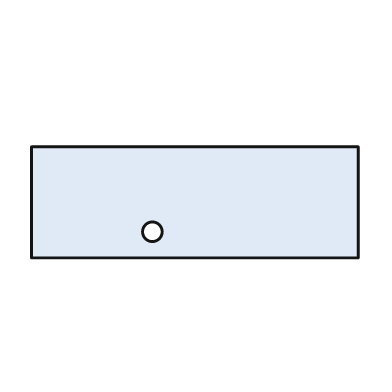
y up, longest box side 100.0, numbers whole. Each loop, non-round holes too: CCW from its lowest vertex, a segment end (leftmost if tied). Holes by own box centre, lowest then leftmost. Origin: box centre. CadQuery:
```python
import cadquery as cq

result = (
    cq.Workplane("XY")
    .moveTo(-50.0, -17.0)
    .lineTo(50.0, -17.0)
    .lineTo(50.0, 17.0)
    .lineTo(-50.0, 17.0)
    .close()
    .moveTo(-13.0, -9.0)
    .circle(3.0)
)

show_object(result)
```